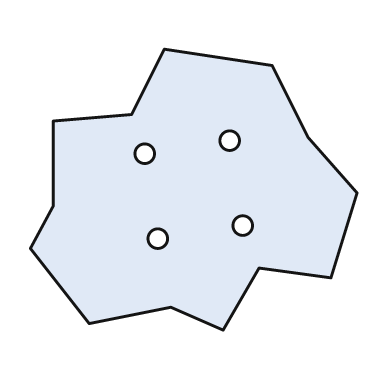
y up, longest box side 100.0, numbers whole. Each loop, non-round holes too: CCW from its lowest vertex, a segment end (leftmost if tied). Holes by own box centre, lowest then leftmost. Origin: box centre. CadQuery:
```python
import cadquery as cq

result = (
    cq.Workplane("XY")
    .moveTo(9.0, -43.0)
    .lineTo(20.0, -24.0)
    .lineTo(42.0, -27.0)
    .lineTo(50.0, -1.0)
    .lineTo(35.0, 16.0)
    .lineTo(24.0, 38.0)
    .lineTo(-9.0, 43.0)
    .lineTo(-19.0, 23.0)
    .lineTo(-43.0, 21.0)
    .lineTo(-43.0, -5.0)
    .lineTo(-50.0, -18.0)
    .lineTo(-32.0, -41.0)
    .lineTo(-7.0, -36.0)
    .close()
    .moveTo(-11.0, -15.0)
    .circle(3.0)
    .moveTo(15.0, -11.0)
    .circle(3.0)
    .moveTo(-15.0, 11.0)
    .circle(3.0)
    .moveTo(11.0, 15.0)
    .circle(3.0)
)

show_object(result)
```